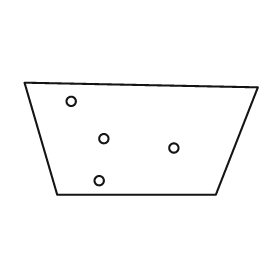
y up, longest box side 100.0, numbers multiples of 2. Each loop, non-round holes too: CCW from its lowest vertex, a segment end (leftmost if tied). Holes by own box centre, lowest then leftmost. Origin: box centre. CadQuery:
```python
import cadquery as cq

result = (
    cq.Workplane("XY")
    .moveTo(-36.0, -24.0)
    .lineTo(32.0, -24.0)
    .lineTo(50.0, 22.0)
    .lineTo(-50.0, 24.0)
    .close()
    .moveTo(-18.0, -18.0)
    .circle(2.0)
    .moveTo(14.0, -4.0)
    .circle(2.0)
    .moveTo(-16.0, 0.0)
    .circle(2.0)
    .moveTo(-30.0, 16.0)
    .circle(2.0)
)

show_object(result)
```